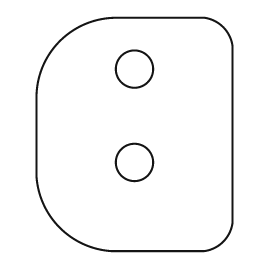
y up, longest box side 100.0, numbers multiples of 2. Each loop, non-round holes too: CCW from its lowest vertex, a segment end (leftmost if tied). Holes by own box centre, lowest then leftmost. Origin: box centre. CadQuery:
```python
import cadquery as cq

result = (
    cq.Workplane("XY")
    .moveTo(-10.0, -50.0)
    .lineTo(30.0, -50.0)
    .threePointArc((38.0, -46.0), (42.0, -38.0))
    .lineTo(42.0, 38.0)
    .threePointArc((38.0, 46.0), (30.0, 50.0))
    .lineTo(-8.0, 50.0)
    .threePointArc((-32.0, 40.0), (-42.0, 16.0))
    .lineTo(-42.0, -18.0)
    .threePointArc((-32.0, -40.0), (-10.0, -50.0))
    .close()
    .moveTo(0.0, -12.0)
    .circle(8.0)
    .moveTo(0.0, 28.0)
    .circle(8.0)
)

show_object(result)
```